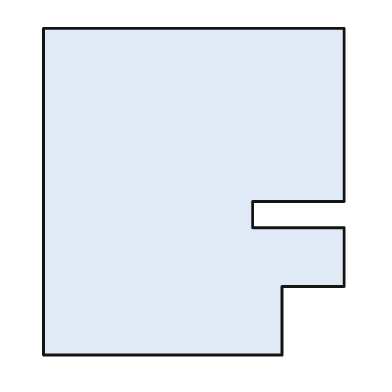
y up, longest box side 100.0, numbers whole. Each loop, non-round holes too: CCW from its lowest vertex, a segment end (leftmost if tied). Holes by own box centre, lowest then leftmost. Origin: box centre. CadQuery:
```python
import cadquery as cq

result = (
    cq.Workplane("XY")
    .moveTo(-46.0, -50.0)
    .lineTo(27.0, -50.0)
    .lineTo(27.0, -29.0)
    .lineTo(46.0, -29.0)
    .lineTo(46.0, -11.0)
    .lineTo(18.0, -11.0)
    .lineTo(18.0, -3.0)
    .lineTo(46.0, -3.0)
    .lineTo(46.0, 50.0)
    .lineTo(-46.0, 50.0)
    .close()
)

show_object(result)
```